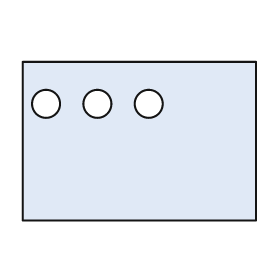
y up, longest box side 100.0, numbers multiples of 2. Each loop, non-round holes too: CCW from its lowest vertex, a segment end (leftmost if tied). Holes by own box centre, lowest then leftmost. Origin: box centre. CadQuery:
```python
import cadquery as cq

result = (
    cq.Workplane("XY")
    .moveTo(-50.0, -34.0)
    .lineTo(50.0, -34.0)
    .lineTo(50.0, 34.0)
    .lineTo(-50.0, 34.0)
    .close()
    .moveTo(-40.0, 16.0)
    .circle(6.0)
    .moveTo(-18.0, 16.0)
    .circle(6.0)
    .moveTo(4.0, 16.0)
    .circle(6.0)
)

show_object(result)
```